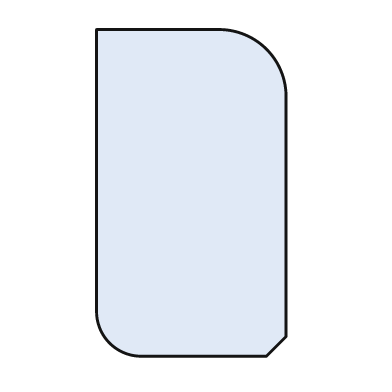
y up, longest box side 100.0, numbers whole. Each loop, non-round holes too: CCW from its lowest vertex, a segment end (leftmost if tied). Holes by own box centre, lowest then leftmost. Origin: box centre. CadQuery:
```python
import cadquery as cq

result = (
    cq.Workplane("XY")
    .moveTo(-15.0, -50.0)
    .lineTo(23.0, -50.0)
    .lineTo(29.0, -44.0)
    .lineTo(29.0, 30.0)
    .threePointArc((23.0, 44.0), (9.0, 50.0))
    .lineTo(-29.0, 50.0)
    .lineTo(-29.0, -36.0)
    .threePointArc((-25.0, -46.0), (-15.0, -50.0))
    .close()
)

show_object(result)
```